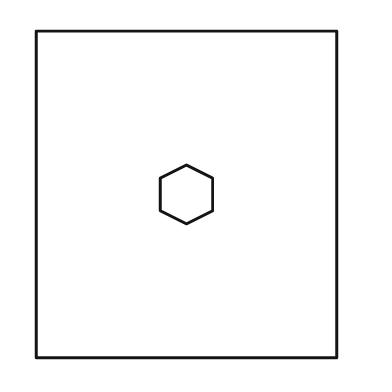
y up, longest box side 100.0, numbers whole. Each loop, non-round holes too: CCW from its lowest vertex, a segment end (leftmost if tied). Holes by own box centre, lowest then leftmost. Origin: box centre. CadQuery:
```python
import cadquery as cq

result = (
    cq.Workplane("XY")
    .moveTo(-46.0, -50.0)
    .lineTo(46.0, -50.0)
    .lineTo(46.0, 50.0)
    .lineTo(-46.0, 50.0)
    .close()
    .moveTo(0.0, -9.0)
    .lineTo(8.0, -5.0)
    .lineTo(8.0, 5.0)
    .lineTo(0.0, 9.0)
    .lineTo(-8.0, 5.0)
    .lineTo(-8.0, -5.0)
    .close()
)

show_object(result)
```